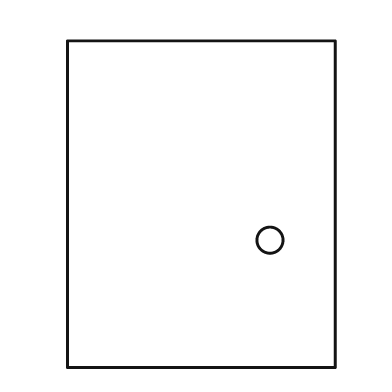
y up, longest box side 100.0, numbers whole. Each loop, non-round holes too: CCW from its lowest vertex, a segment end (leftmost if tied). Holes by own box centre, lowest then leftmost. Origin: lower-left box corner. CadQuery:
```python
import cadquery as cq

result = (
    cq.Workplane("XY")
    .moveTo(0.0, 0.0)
    .lineTo(82.0, 0.0)
    .lineTo(82.0, 100.0)
    .lineTo(0.0, 100.0)
    .close()
    .moveTo(62.0, 39.0)
    .circle(4.0)
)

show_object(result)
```